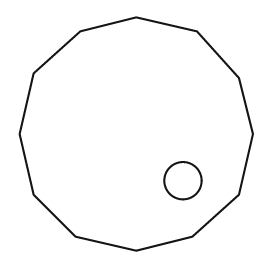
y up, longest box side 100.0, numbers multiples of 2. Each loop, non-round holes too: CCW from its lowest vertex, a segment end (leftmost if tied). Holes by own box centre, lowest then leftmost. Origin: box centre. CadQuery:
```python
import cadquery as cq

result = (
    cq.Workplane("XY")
    .moveTo(0.0, -50.0)
    .lineTo(24.0, -44.0)
    .lineTo(44.0, -26.0)
    .lineTo(50.0, 0.0)
    .lineTo(44.0, 24.0)
    .lineTo(26.0, 44.0)
    .lineTo(0.0, 50.0)
    .lineTo(-24.0, 44.0)
    .lineTo(-44.0, 26.0)
    .lineTo(-50.0, 0.0)
    .lineTo(-44.0, -26.0)
    .lineTo(-26.0, -44.0)
    .close()
    .moveTo(20.0, -20.0)
    .circle(8.0)
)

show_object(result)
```